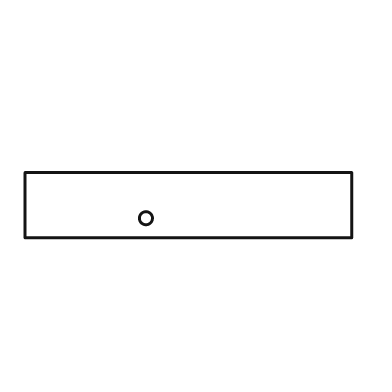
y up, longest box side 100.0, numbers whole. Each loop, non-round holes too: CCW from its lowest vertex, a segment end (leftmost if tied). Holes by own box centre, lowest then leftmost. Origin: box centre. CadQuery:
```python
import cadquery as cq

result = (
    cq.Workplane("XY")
    .moveTo(-50.0, -10.0)
    .lineTo(50.0, -10.0)
    .lineTo(50.0, 10.0)
    .lineTo(-50.0, 10.0)
    .close()
    .moveTo(-13.0, -4.0)
    .circle(2.0)
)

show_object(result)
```